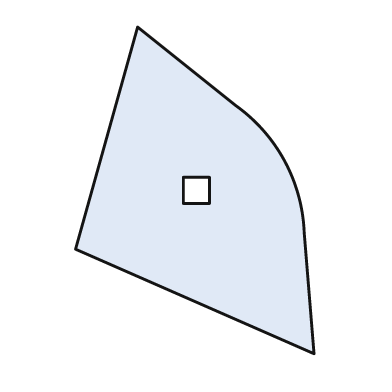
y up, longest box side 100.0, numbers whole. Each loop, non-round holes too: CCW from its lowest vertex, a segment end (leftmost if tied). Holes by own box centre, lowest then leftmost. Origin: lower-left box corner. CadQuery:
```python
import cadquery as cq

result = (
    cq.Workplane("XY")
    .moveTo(73.0, 0.0)
    .lineTo(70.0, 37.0)
    .threePointArc((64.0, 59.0), (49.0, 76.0))
    .lineTo(19.0, 100.0)
    .lineTo(0.0, 32.0)
    .close()
    .moveTo(33.0, 46.0)
    .lineTo(41.0, 46.0)
    .lineTo(41.0, 54.0)
    .lineTo(33.0, 54.0)
    .close()
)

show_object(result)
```